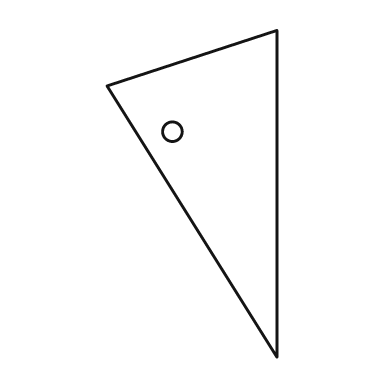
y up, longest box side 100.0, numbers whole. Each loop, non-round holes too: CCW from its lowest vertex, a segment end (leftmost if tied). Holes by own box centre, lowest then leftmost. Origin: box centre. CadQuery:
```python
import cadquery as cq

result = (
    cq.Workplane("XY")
    .moveTo(26.0, -50.0)
    .lineTo(26.0, 50.0)
    .lineTo(-26.0, 33.0)
    .close()
    .moveTo(-6.0, 19.0)
    .circle(3.0)
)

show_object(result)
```